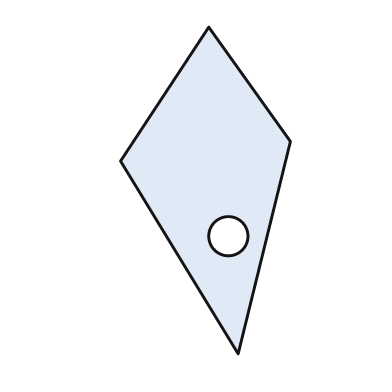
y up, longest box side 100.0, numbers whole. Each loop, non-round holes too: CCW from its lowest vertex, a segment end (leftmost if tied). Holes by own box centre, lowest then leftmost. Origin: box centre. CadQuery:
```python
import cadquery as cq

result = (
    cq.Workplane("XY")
    .moveTo(10.0, -50.0)
    .lineTo(26.0, 15.0)
    .lineTo(1.0, 50.0)
    .lineTo(-26.0, 9.0)
    .close()
    .moveTo(7.0, -14.0)
    .circle(6.0)
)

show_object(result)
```